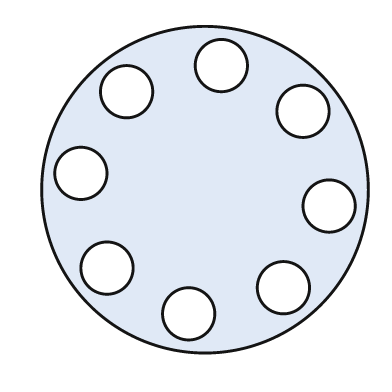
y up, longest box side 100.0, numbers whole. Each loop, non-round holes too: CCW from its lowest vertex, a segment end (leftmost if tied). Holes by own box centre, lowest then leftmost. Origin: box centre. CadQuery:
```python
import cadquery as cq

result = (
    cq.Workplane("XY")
    .moveTo(0.0, 0.0)
    .circle(50.0)
    .moveTo(-5.0, -38.0)
    .circle(8.0)
    .moveTo(24.0, -30.0)
    .circle(8.0)
    .moveTo(-30.0, -24.0)
    .circle(8.0)
    .moveTo(38.0, -5.0)
    .circle(8.0)
    .moveTo(-38.0, 5.0)
    .circle(8.0)
    .moveTo(30.0, 24.0)
    .circle(8.0)
    .moveTo(-24.0, 30.0)
    .circle(8.0)
    .moveTo(5.0, 38.0)
    .circle(8.0)
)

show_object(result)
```